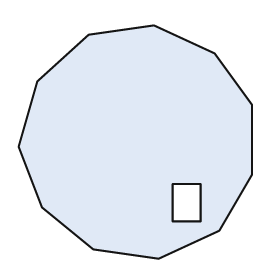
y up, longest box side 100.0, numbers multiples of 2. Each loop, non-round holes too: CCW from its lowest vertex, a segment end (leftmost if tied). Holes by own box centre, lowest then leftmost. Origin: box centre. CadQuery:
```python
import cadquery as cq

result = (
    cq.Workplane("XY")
    .moveTo(10.0, -50.0)
    .lineTo(36.0, -38.0)
    .lineTo(50.0, -14.0)
    .lineTo(50.0, 16.0)
    .lineTo(34.0, 38.0)
    .lineTo(8.0, 50.0)
    .lineTo(-20.0, 46.0)
    .lineTo(-42.0, 26.0)
    .lineTo(-50.0, -2.0)
    .lineTo(-40.0, -28.0)
    .lineTo(-18.0, -46.0)
    .close()
    .moveTo(16.0, -34.0)
    .lineTo(28.0, -34.0)
    .lineTo(28.0, -18.0)
    .lineTo(16.0, -18.0)
    .close()
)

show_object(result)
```